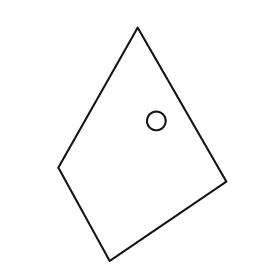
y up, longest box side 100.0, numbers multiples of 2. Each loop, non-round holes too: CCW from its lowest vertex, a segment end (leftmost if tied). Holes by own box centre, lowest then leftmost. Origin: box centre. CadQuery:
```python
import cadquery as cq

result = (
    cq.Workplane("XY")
    .moveTo(-14.0, -50.0)
    .lineTo(36.0, -16.0)
    .lineTo(-2.0, 50.0)
    .lineTo(-36.0, -10.0)
    .close()
    .moveTo(6.0, 10.0)
    .circle(4.0)
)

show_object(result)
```